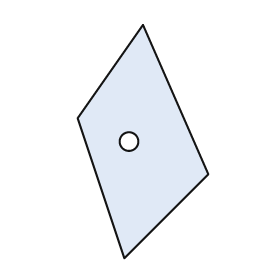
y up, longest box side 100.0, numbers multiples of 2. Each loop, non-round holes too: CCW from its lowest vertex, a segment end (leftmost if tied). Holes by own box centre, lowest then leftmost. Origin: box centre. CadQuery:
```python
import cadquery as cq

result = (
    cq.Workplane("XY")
    .moveTo(-8.0, -50.0)
    .lineTo(28.0, -14.0)
    .lineTo(0.0, 50.0)
    .lineTo(-28.0, 10.0)
    .close()
    .moveTo(-6.0, 0.0)
    .circle(4.0)
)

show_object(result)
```